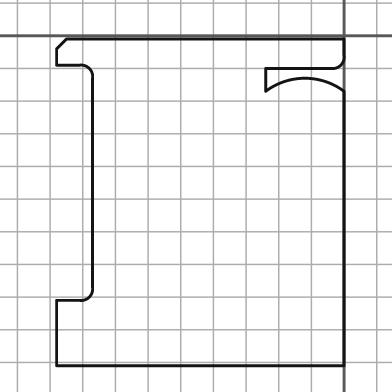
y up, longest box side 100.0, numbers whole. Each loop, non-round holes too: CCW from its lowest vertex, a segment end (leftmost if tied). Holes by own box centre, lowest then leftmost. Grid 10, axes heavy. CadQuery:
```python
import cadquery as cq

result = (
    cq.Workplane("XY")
    .moveTo(-88.0, -101.0)
    .lineTo(0.0, -101.0)
    .lineTo(0.0, -17.0)
    .threePointArc((-12.0, -13.0), (-24.0, -17.0))
    .lineTo(-24.0, -10.0)
    .lineTo(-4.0, -10.0)
    .threePointArc((-1.0, -9.0), (0.0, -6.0))
    .lineTo(0.0, -1.0)
    .lineTo(-85.0, -1.0)
    .lineTo(-88.0, -4.0)
    .lineTo(-88.0, -9.0)
    .lineTo(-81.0, -9.0)
    .threePointArc((-78.0, -10.0), (-77.0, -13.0))
    .lineTo(-77.0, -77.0)
    .threePointArc((-78.0, -80.0), (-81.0, -81.0))
    .lineTo(-88.0, -81.0)
    .close()
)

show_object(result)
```